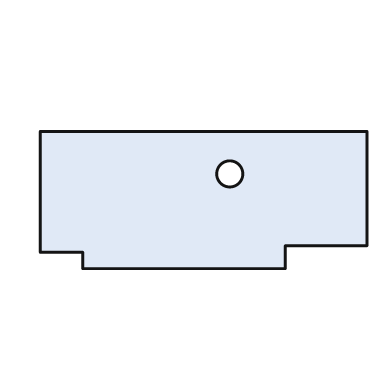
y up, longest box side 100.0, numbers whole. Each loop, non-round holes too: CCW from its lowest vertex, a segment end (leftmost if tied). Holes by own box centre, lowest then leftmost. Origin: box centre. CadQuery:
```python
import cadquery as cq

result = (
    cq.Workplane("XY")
    .moveTo(-37.0, -21.0)
    .lineTo(25.0, -21.0)
    .lineTo(25.0, -14.0)
    .lineTo(50.0, -14.0)
    .lineTo(50.0, 21.0)
    .lineTo(-50.0, 21.0)
    .lineTo(-50.0, -16.0)
    .lineTo(-37.0, -16.0)
    .close()
    .moveTo(8.0, 8.0)
    .circle(4.0)
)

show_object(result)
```